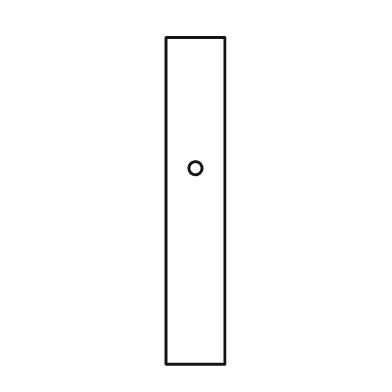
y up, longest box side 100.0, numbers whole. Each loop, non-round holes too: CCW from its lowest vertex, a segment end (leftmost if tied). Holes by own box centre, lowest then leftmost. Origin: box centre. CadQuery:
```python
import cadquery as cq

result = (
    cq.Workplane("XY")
    .moveTo(-9.0, -50.0)
    .lineTo(9.0, -50.0)
    .lineTo(9.0, 50.0)
    .lineTo(-9.0, 50.0)
    .close()
    .moveTo(0.0, 10.0)
    .circle(2.0)
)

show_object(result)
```